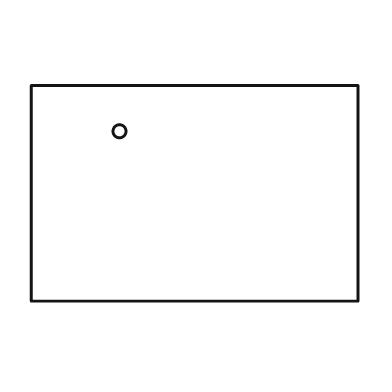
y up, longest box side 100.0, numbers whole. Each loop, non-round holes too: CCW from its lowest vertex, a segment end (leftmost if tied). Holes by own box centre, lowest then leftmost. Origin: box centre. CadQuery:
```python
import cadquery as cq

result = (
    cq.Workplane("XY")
    .moveTo(-50.0, -33.0)
    .lineTo(50.0, -33.0)
    .lineTo(50.0, 33.0)
    .lineTo(-50.0, 33.0)
    .close()
    .moveTo(-23.0, 19.0)
    .circle(2.0)
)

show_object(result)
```